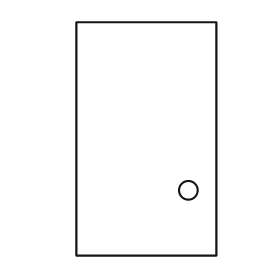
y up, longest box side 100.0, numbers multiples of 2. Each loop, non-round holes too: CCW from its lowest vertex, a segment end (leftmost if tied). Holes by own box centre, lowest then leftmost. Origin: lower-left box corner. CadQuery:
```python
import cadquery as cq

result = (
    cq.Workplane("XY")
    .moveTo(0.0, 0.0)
    .lineTo(60.0, 0.0)
    .lineTo(60.0, 100.0)
    .lineTo(0.0, 100.0)
    .close()
    .moveTo(48.0, 28.0)
    .circle(4.0)
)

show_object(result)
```